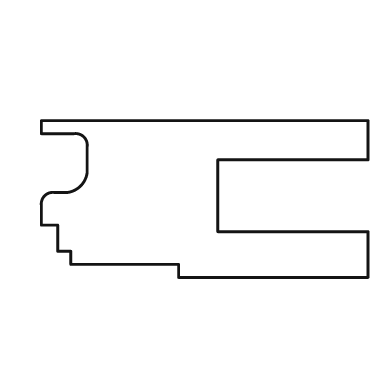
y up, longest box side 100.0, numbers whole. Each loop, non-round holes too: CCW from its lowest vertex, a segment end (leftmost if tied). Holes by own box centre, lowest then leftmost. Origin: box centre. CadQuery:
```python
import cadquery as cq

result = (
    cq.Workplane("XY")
    .moveTo(-8.0, -24.0)
    .lineTo(50.0, -24.0)
    .lineTo(50.0, -10.0)
    .lineTo(4.0, -10.0)
    .lineTo(4.0, 12.0)
    .lineTo(50.0, 12.0)
    .lineTo(50.0, 24.0)
    .lineTo(-50.0, 24.0)
    .lineTo(-50.0, 20.0)
    .lineTo(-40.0, 20.0)
    .threePointArc((-37.0, 19.0), (-36.0, 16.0))
    .lineTo(-36.0, 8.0)
    .threePointArc((-38.0, 4.0), (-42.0, 2.0))
    .lineTo(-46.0, 2.0)
    .threePointArc((-49.0, 1.0), (-50.0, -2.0))
    .lineTo(-50.0, -8.0)
    .lineTo(-45.0, -8.0)
    .lineTo(-45.0, -16.0)
    .lineTo(-41.0, -16.0)
    .lineTo(-41.0, -20.0)
    .lineTo(-8.0, -20.0)
    .close()
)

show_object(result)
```